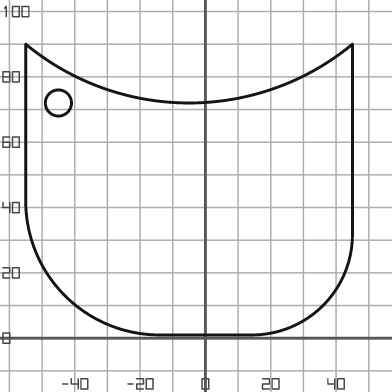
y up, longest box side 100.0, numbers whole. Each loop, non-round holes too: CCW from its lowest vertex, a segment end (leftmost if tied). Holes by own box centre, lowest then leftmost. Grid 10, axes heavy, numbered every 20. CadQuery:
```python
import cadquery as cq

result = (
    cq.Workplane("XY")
    .moveTo(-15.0, 1.0)
    .lineTo(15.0, 1.0)
    .threePointArc((36.0, 10.0), (45.0, 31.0))
    .lineTo(45.0, 90.0)
    .threePointArc((-5.0, 72.0), (-55.0, 90.0))
    .lineTo(-55.0, 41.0)
    .threePointArc((-43.0, 13.0), (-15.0, 1.0))
    .close()
    .moveTo(-45.0, 72.0)
    .circle(4.0)
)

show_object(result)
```